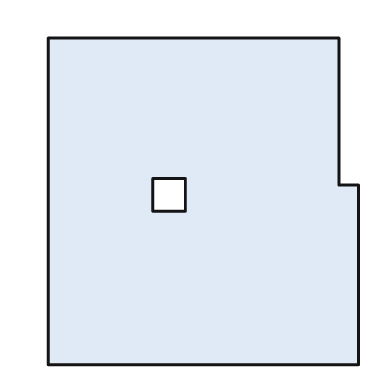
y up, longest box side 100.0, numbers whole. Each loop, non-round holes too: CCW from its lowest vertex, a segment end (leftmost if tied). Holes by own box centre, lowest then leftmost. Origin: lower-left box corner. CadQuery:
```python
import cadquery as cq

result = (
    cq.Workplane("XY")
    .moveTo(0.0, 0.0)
    .lineTo(95.0, 0.0)
    .lineTo(95.0, 55.0)
    .lineTo(89.0, 55.0)
    .lineTo(89.0, 100.0)
    .lineTo(0.0, 100.0)
    .close()
    .moveTo(32.0, 47.0)
    .lineTo(42.0, 47.0)
    .lineTo(42.0, 57.0)
    .lineTo(32.0, 57.0)
    .close()
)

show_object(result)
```